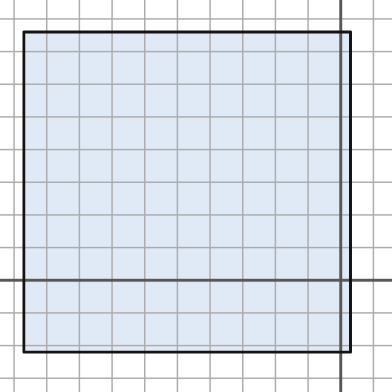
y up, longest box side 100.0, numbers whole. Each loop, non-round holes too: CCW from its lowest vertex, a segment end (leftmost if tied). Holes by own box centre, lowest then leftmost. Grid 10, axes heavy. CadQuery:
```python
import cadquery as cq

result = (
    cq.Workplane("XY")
    .moveTo(-97.0, -22.0)
    .lineTo(3.0, -22.0)
    .lineTo(3.0, 76.0)
    .lineTo(-97.0, 76.0)
    .close()
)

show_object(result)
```